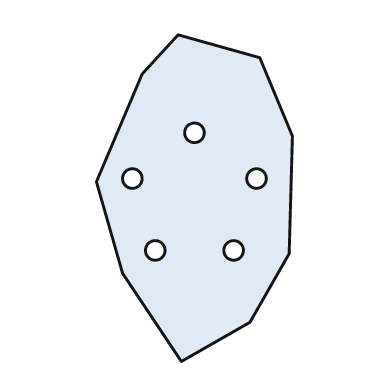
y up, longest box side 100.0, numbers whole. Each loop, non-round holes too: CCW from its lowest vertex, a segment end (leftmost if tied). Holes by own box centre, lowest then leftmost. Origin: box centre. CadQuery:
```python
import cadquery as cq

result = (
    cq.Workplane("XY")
    .moveTo(-4.0, -50.0)
    .lineTo(17.0, -38.0)
    .lineTo(29.0, -17.0)
    .lineTo(30.0, 19.0)
    .lineTo(20.0, 43.0)
    .lineTo(-5.0, 50.0)
    .lineTo(-16.0, 38.0)
    .lineTo(-30.0, 5.0)
    .lineTo(-22.0, -23.0)
    .close()
    .moveTo(-12.0, -16.0)
    .circle(3.0)
    .moveTo(12.0, -16.0)
    .circle(3.0)
    .moveTo(-19.0, 6.0)
    .circle(3.0)
    .moveTo(19.0, 6.0)
    .circle(3.0)
    .moveTo(0.0, 20.0)
    .circle(3.0)
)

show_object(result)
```